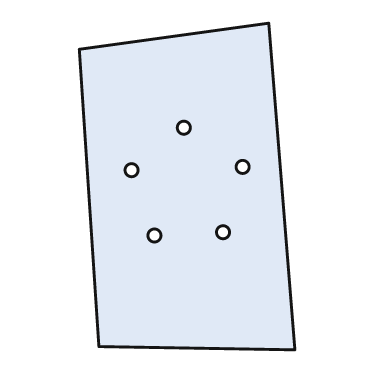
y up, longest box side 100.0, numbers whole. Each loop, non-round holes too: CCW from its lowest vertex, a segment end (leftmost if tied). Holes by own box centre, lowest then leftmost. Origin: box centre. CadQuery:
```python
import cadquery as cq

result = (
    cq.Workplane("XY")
    .moveTo(33.0, -50.0)
    .lineTo(25.0, 50.0)
    .lineTo(-33.0, 42.0)
    .lineTo(-27.0, -49.0)
    .close()
    .moveTo(-10.0, -15.0)
    .circle(2.0)
    .moveTo(11.0, -14.0)
    .circle(2.0)
    .moveTo(-17.0, 5.0)
    .circle(2.0)
    .moveTo(17.0, 6.0)
    .circle(2.0)
    .moveTo(-1.0, 18.0)
    .circle(2.0)
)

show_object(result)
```